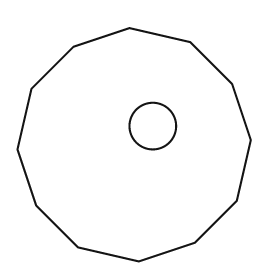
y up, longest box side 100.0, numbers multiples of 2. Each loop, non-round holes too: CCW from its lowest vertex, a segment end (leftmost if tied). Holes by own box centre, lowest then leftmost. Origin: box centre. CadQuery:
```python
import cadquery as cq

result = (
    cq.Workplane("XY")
    .moveTo(2.0, -50.0)
    .lineTo(26.0, -42.0)
    .lineTo(44.0, -24.0)
    .lineTo(50.0, 2.0)
    .lineTo(42.0, 26.0)
    .lineTo(24.0, 44.0)
    .lineTo(-2.0, 50.0)
    .lineTo(-26.0, 42.0)
    .lineTo(-44.0, 24.0)
    .lineTo(-50.0, -2.0)
    .lineTo(-42.0, -26.0)
    .lineTo(-24.0, -44.0)
    .close()
    .moveTo(8.0, 8.0)
    .circle(10.0)
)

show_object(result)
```